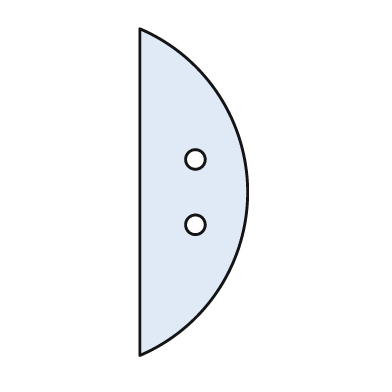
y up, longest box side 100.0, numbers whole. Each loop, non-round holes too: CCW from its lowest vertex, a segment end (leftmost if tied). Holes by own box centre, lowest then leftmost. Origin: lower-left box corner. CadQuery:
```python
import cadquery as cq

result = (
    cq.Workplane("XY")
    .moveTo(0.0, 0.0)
    .threePointArc((33.0, 50.0), (0.0, 100.0))
    .close()
    .moveTo(17.0, 40.0)
    .circle(3.0)
    .moveTo(17.0, 60.0)
    .circle(3.0)
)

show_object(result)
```